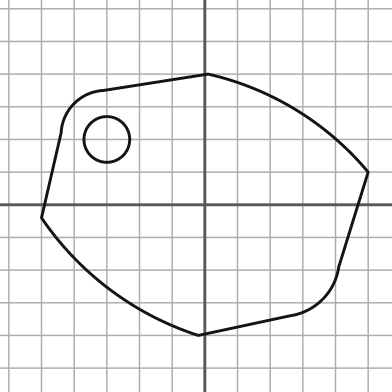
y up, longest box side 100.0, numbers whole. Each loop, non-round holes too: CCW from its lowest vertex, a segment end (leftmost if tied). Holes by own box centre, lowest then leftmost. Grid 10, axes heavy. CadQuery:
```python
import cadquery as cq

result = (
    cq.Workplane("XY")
    .moveTo(-2.0, -40.0)
    .lineTo(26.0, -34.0)
    .threePointArc((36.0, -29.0), (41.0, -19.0))
    .lineTo(50.0, 10.0)
    .threePointArc((28.0, 29.0), (1.0, 40.0))
    .lineTo(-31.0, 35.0)
    .threePointArc((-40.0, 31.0), (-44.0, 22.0))
    .lineTo(-50.0, -4.0)
    .threePointArc((-29.0, -26.0), (-2.0, -40.0))
    .close()
    .moveTo(-30.0, 20.0)
    .circle(7.0)
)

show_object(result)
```